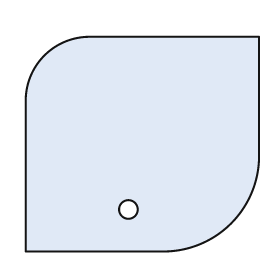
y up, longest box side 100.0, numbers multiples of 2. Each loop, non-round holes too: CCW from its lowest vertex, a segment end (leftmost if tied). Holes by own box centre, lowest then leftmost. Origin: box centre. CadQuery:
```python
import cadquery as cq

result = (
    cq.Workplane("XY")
    .moveTo(-50.0, -46.0)
    .lineTo(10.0, -46.0)
    .threePointArc((38.0, -34.0), (50.0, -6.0))
    .lineTo(50.0, 46.0)
    .lineTo(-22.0, 46.0)
    .threePointArc((-42.0, 38.0), (-50.0, 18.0))
    .close()
    .moveTo(-6.0, -28.0)
    .circle(4.0)
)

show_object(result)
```